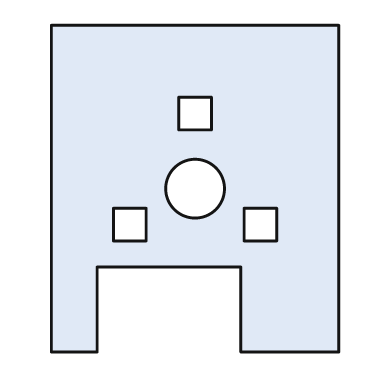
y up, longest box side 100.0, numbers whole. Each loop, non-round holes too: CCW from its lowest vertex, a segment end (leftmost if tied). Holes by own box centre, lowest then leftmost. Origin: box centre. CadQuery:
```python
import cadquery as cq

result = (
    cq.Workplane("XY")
    .moveTo(-44.0, -50.0)
    .lineTo(-30.0, -50.0)
    .lineTo(-30.0, -24.0)
    .lineTo(14.0, -24.0)
    .lineTo(14.0, -50.0)
    .lineTo(44.0, -50.0)
    .lineTo(44.0, 50.0)
    .lineTo(-44.0, 50.0)
    .close()
    .moveTo(-25.0, -16.0)
    .lineTo(-15.0, -16.0)
    .lineTo(-15.0, -6.0)
    .lineTo(-25.0, -6.0)
    .close()
    .moveTo(15.0, -16.0)
    .lineTo(25.0, -16.0)
    .lineTo(25.0, -6.0)
    .lineTo(15.0, -6.0)
    .close()
    .moveTo(0.0, 0.0)
    .circle(9.0)
    .moveTo(-5.0, 18.0)
    .lineTo(5.0, 18.0)
    .lineTo(5.0, 28.0)
    .lineTo(-5.0, 28.0)
    .close()
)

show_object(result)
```